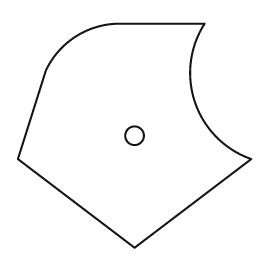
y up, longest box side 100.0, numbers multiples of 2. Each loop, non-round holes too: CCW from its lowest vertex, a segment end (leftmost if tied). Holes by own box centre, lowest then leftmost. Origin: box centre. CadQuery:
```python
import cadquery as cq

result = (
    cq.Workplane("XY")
    .moveTo(0.0, -48.0)
    .lineTo(50.0, -10.0)
    .threePointArc((26.0, 14.0), (30.0, 48.0))
    .lineTo(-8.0, 48.0)
    .threePointArc((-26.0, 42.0), (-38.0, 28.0))
    .lineTo(-50.0, -10.0)
    .close()
    .moveTo(0.0, 0.0)
    .circle(4.0)
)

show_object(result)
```